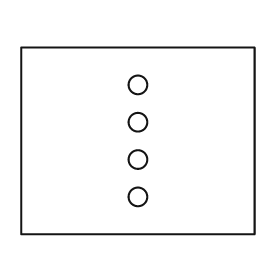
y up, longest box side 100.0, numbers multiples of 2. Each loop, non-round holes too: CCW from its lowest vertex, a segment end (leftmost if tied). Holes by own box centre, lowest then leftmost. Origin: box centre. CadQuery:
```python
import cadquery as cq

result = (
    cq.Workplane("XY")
    .moveTo(-50.0, -40.0)
    .lineTo(50.0, -40.0)
    .lineTo(50.0, 40.0)
    .lineTo(-50.0, 40.0)
    .close()
    .moveTo(0.0, -24.0)
    .circle(4.0)
    .moveTo(0.0, -8.0)
    .circle(4.0)
    .moveTo(0.0, 8.0)
    .circle(4.0)
    .moveTo(0.0, 24.0)
    .circle(4.0)
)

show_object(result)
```